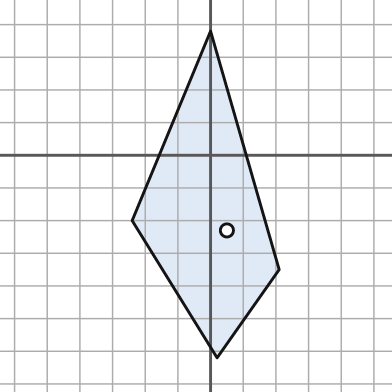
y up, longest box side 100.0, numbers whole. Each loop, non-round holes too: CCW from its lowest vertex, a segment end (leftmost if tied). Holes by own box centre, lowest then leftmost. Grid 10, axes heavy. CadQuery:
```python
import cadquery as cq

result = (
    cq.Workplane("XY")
    .moveTo(2.0, -62.0)
    .lineTo(21.0, -35.0)
    .lineTo(0.0, 38.0)
    .lineTo(-24.0, -20.0)
    .close()
    .moveTo(5.0, -23.0)
    .circle(2.0)
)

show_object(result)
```